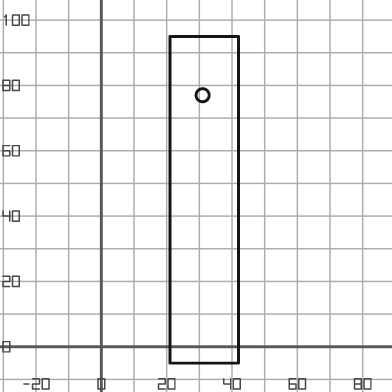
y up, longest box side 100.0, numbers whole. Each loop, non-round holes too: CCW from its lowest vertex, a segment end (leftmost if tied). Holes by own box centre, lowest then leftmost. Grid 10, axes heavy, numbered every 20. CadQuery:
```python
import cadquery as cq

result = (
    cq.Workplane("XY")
    .moveTo(21.0, -5.0)
    .lineTo(42.0, -5.0)
    .lineTo(42.0, 95.0)
    .lineTo(21.0, 95.0)
    .close()
    .moveTo(31.0, 77.0)
    .circle(2.0)
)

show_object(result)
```